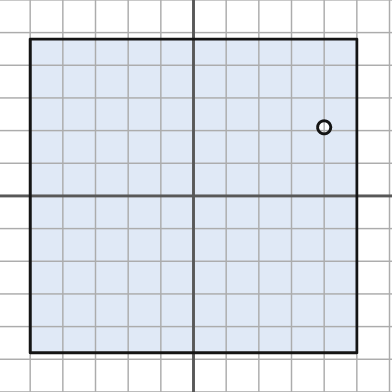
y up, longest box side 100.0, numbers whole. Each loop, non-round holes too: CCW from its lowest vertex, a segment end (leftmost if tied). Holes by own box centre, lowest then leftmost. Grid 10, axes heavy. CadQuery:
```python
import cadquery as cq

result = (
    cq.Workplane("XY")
    .moveTo(-50.0, -48.0)
    .lineTo(50.0, -48.0)
    .lineTo(50.0, 48.0)
    .lineTo(-50.0, 48.0)
    .close()
    .moveTo(40.0, 21.0)
    .circle(2.0)
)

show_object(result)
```